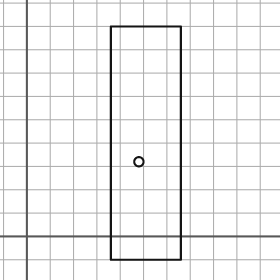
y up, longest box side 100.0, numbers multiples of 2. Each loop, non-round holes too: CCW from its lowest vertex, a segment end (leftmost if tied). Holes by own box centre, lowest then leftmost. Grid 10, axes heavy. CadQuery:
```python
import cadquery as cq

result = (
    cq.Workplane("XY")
    .moveTo(36.0, -10.0)
    .lineTo(66.0, -10.0)
    .lineTo(66.0, 90.0)
    .lineTo(36.0, 90.0)
    .close()
    .moveTo(48.0, 32.0)
    .circle(2.0)
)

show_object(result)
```